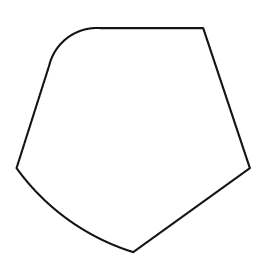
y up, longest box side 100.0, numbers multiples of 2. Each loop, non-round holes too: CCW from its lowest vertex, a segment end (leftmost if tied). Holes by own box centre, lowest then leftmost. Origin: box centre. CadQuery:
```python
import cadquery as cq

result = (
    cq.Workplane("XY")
    .moveTo(0.0, -48.0)
    .lineTo(50.0, -12.0)
    .lineTo(30.0, 48.0)
    .lineTo(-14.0, 48.0)
    .threePointArc((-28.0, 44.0), (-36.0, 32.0))
    .lineTo(-50.0, -12.0)
    .threePointArc((-28.0, -34.0), (0.0, -48.0))
    .close()
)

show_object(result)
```